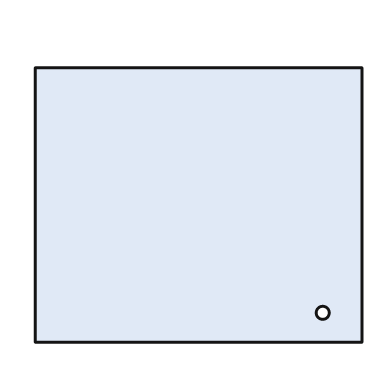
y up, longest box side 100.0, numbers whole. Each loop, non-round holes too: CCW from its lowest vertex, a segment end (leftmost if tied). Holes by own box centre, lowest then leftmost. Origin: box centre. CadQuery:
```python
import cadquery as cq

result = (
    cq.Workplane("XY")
    .moveTo(-50.0, -42.0)
    .lineTo(50.0, -42.0)
    .lineTo(50.0, 42.0)
    .lineTo(-50.0, 42.0)
    .close()
    .moveTo(38.0, -33.0)
    .circle(2.0)
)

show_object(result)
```